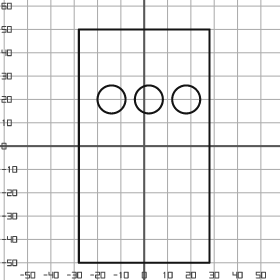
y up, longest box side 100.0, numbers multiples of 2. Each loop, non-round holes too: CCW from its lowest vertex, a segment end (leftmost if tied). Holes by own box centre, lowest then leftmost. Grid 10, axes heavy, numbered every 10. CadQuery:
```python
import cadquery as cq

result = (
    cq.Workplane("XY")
    .moveTo(-28.0, -50.0)
    .lineTo(28.0, -50.0)
    .lineTo(28.0, 50.0)
    .lineTo(-28.0, 50.0)
    .close()
    .moveTo(-14.0, 20.0)
    .circle(6.0)
    .moveTo(2.0, 20.0)
    .circle(6.0)
    .moveTo(18.0, 20.0)
    .circle(6.0)
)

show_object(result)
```